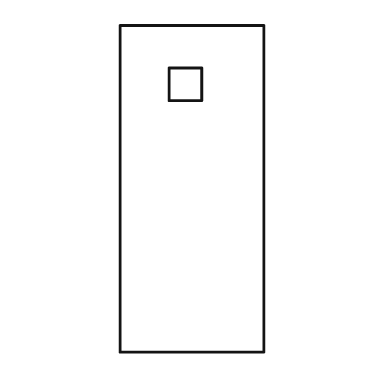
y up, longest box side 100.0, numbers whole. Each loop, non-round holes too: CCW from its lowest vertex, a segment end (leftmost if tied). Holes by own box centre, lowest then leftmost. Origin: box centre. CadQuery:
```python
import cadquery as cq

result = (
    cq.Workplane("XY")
    .moveTo(-22.0, -50.0)
    .lineTo(22.0, -50.0)
    .lineTo(22.0, 50.0)
    .lineTo(-22.0, 50.0)
    .close()
    .moveTo(-7.0, 27.0)
    .lineTo(3.0, 27.0)
    .lineTo(3.0, 37.0)
    .lineTo(-7.0, 37.0)
    .close()
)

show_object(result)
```